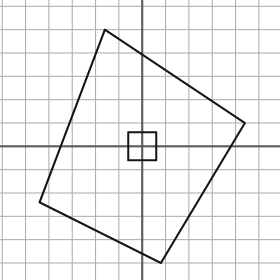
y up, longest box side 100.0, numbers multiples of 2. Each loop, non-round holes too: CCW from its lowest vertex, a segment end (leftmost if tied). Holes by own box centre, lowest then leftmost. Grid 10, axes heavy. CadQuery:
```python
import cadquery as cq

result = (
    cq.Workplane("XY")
    .moveTo(8.0, -50.0)
    .lineTo(44.0, 10.0)
    .lineTo(-16.0, 50.0)
    .lineTo(-44.0, -24.0)
    .close()
    .moveTo(-6.0, -6.0)
    .lineTo(6.0, -6.0)
    .lineTo(6.0, 6.0)
    .lineTo(-6.0, 6.0)
    .close()
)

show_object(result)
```